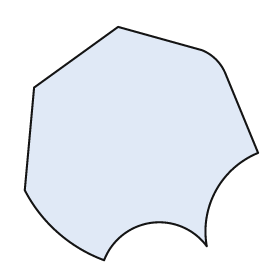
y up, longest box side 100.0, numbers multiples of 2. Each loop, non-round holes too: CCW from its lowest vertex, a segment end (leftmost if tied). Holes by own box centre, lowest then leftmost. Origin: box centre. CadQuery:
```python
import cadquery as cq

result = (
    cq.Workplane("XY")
    .moveTo(-16.0, -50.0)
    .threePointArc((4.0, -34.0), (28.0, -44.0))
    .threePointArc((32.0, -20.0), (50.0, -4.0))
    .lineTo(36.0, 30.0)
    .threePointArc((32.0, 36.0), (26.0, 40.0))
    .lineTo(-10.0, 50.0)
    .lineTo(-46.0, 24.0)
    .lineTo(-50.0, -20.0)
    .threePointArc((-36.0, -38.0), (-16.0, -50.0))
    .close()
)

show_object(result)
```